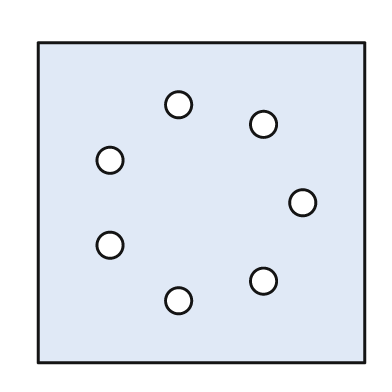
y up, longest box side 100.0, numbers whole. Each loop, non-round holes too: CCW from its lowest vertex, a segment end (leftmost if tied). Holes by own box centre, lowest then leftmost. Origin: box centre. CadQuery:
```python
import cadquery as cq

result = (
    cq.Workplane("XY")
    .moveTo(-50.0, -49.0)
    .lineTo(50.0, -49.0)
    .lineTo(50.0, 49.0)
    .lineTo(-50.0, 49.0)
    .close()
    .moveTo(-7.0, -30.0)
    .circle(4.0)
    .moveTo(19.0, -24.0)
    .circle(4.0)
    .moveTo(-28.0, -13.0)
    .circle(4.0)
    .moveTo(31.0, 0.0)
    .circle(4.0)
    .moveTo(-28.0, 13.0)
    .circle(4.0)
    .moveTo(19.0, 24.0)
    .circle(4.0)
    .moveTo(-7.0, 30.0)
    .circle(4.0)
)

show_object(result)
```